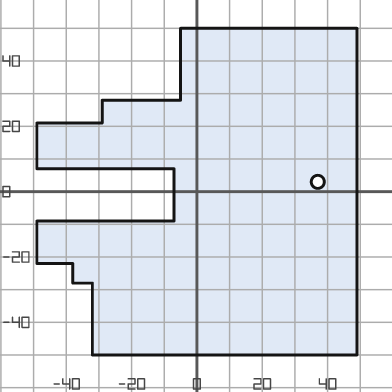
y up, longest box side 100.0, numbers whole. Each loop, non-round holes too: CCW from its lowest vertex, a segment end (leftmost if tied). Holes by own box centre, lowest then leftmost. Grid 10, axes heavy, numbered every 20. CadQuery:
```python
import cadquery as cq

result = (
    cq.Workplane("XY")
    .moveTo(-32.0, -50.0)
    .lineTo(49.0, -50.0)
    .lineTo(49.0, 50.0)
    .lineTo(-5.0, 50.0)
    .lineTo(-5.0, 28.0)
    .lineTo(-29.0, 28.0)
    .lineTo(-29.0, 21.0)
    .lineTo(-49.0, 21.0)
    .lineTo(-49.0, 7.0)
    .lineTo(-7.0, 7.0)
    .lineTo(-7.0, -9.0)
    .lineTo(-49.0, -9.0)
    .lineTo(-49.0, -22.0)
    .lineTo(-38.0, -22.0)
    .lineTo(-38.0, -28.0)
    .lineTo(-32.0, -28.0)
    .close()
    .moveTo(37.0, 3.0)
    .circle(2.0)
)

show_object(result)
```